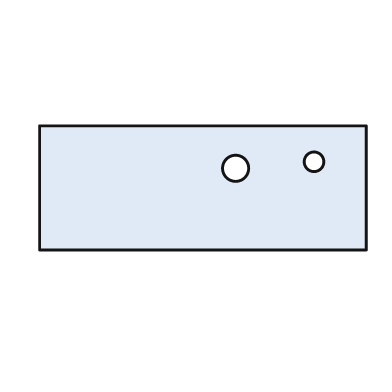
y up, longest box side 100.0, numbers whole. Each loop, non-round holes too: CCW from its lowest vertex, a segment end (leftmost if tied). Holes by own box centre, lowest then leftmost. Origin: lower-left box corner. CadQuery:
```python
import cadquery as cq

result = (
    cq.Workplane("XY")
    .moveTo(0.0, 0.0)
    .lineTo(100.0, 0.0)
    .lineTo(100.0, 38.0)
    .lineTo(0.0, 38.0)
    .close()
    .moveTo(60.0, 25.0)
    .circle(4.0)
    .moveTo(84.0, 27.0)
    .circle(3.0)
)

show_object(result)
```